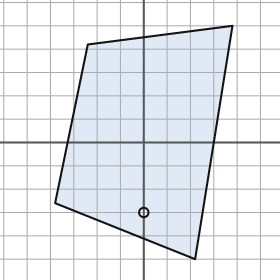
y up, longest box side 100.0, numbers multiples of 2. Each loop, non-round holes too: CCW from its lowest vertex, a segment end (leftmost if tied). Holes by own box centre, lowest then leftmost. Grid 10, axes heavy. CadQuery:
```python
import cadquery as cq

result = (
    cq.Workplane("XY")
    .moveTo(22.0, -50.0)
    .lineTo(38.0, 50.0)
    .lineTo(-24.0, 42.0)
    .lineTo(-38.0, -26.0)
    .close()
    .moveTo(0.0, -30.0)
    .circle(2.0)
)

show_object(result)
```